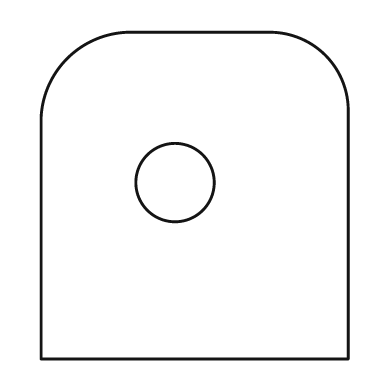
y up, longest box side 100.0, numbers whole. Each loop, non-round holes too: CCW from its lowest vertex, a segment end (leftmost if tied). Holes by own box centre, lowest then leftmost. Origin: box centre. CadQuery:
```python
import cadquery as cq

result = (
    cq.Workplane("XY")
    .moveTo(-47.0, -50.0)
    .lineTo(47.0, -50.0)
    .lineTo(47.0, 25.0)
    .threePointArc((40.0, 43.0), (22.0, 50.0))
    .lineTo(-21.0, 50.0)
    .threePointArc((-39.0, 42.0), (-47.0, 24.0))
    .close()
    .moveTo(-6.0, 4.0)
    .circle(12.0)
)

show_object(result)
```